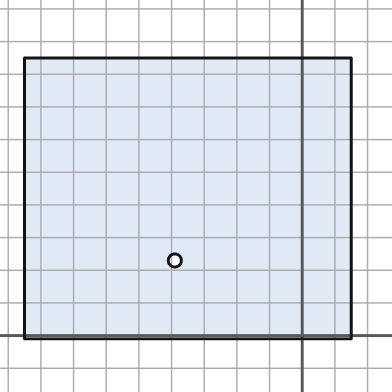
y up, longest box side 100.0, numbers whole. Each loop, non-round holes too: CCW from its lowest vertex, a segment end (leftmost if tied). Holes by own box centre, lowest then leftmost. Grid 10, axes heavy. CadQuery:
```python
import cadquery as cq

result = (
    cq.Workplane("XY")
    .moveTo(-85.0, -1.0)
    .lineTo(15.0, -1.0)
    .lineTo(15.0, 85.0)
    .lineTo(-85.0, 85.0)
    .close()
    .moveTo(-39.0, 23.0)
    .circle(2.0)
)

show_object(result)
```